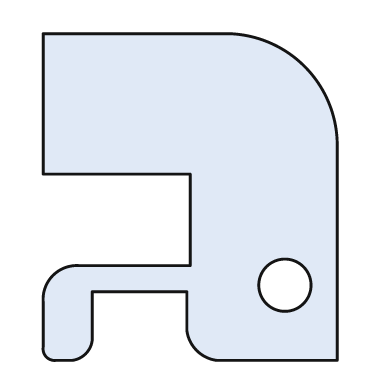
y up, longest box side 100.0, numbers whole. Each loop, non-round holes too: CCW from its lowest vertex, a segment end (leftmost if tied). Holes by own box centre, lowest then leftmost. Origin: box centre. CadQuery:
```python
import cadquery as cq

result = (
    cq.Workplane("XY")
    .moveTo(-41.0, -50.0)
    .lineTo(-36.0, -50.0)
    .threePointArc((-32.0, -48.0), (-30.0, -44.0))
    .lineTo(-30.0, -29.0)
    .lineTo(-1.0, -29.0)
    .lineTo(-1.0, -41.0)
    .threePointArc((2.0, -47.0), (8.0, -50.0))
    .lineTo(45.0, -50.0)
    .lineTo(45.0, 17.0)
    .threePointArc((35.0, 40.0), (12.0, 50.0))
    .lineTo(-45.0, 50.0)
    .lineTo(-45.0, 7.0)
    .lineTo(0.0, 7.0)
    .lineTo(0.0, -21.0)
    .lineTo(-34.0, -21.0)
    .threePointArc((-42.0, -24.0), (-45.0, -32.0))
    .lineTo(-45.0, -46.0)
    .threePointArc((-44.0, -49.0), (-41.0, -50.0))
    .close()
    .moveTo(29.0, -27.0)
    .circle(8.0)
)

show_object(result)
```